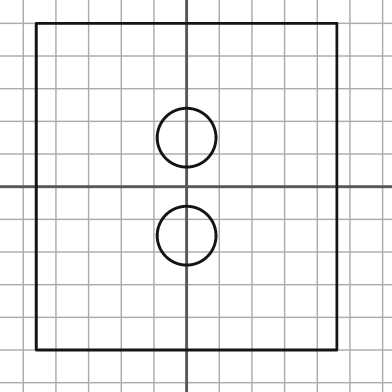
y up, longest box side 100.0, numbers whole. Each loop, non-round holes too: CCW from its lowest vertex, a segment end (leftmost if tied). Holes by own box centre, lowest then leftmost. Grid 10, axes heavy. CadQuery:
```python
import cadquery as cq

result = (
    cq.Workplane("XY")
    .moveTo(-46.0, -50.0)
    .lineTo(46.0, -50.0)
    .lineTo(46.0, 50.0)
    .lineTo(-46.0, 50.0)
    .close()
    .moveTo(0.0, -15.0)
    .circle(9.0)
    .moveTo(0.0, 15.0)
    .circle(9.0)
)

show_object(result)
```